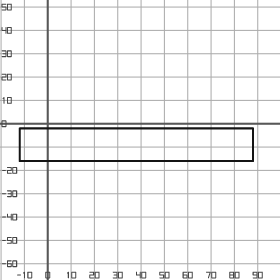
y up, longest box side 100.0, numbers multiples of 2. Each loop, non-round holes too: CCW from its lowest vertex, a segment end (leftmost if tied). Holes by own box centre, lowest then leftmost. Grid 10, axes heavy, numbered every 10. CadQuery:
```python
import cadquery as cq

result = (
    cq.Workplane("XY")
    .moveTo(-12.0, -16.0)
    .lineTo(88.0, -16.0)
    .lineTo(88.0, -2.0)
    .lineTo(-12.0, -2.0)
    .close()
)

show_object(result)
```